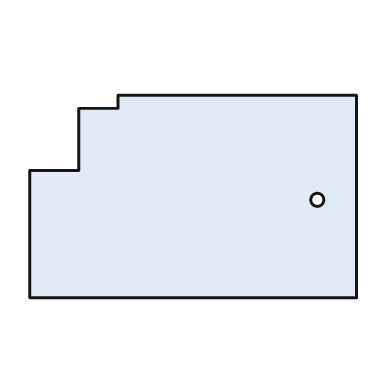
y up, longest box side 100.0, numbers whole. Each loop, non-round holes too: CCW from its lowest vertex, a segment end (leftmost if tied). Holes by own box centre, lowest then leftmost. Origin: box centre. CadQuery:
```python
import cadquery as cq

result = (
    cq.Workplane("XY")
    .moveTo(-50.0, -31.0)
    .lineTo(50.0, -31.0)
    .lineTo(50.0, 31.0)
    .lineTo(-23.0, 31.0)
    .lineTo(-23.0, 27.0)
    .lineTo(-35.0, 27.0)
    .lineTo(-35.0, 8.0)
    .lineTo(-50.0, 8.0)
    .close()
    .moveTo(38.0, -1.0)
    .circle(2.0)
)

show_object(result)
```